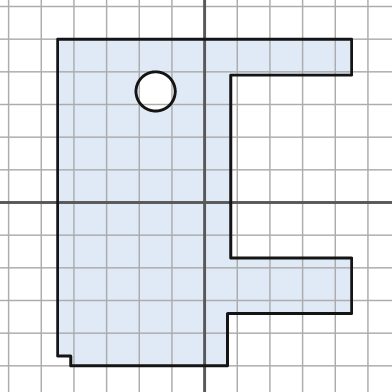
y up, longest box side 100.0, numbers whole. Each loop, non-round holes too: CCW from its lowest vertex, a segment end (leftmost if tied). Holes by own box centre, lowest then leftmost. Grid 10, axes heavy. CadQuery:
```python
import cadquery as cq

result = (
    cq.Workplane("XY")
    .moveTo(-41.0, -50.0)
    .lineTo(7.0, -50.0)
    .lineTo(7.0, -34.0)
    .lineTo(45.0, -34.0)
    .lineTo(45.0, -17.0)
    .lineTo(8.0, -17.0)
    .lineTo(8.0, 39.0)
    .lineTo(45.0, 39.0)
    .lineTo(45.0, 50.0)
    .lineTo(-45.0, 50.0)
    .lineTo(-45.0, -47.0)
    .lineTo(-41.0, -47.0)
    .close()
    .moveTo(-15.0, 34.0)
    .circle(6.0)
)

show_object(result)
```